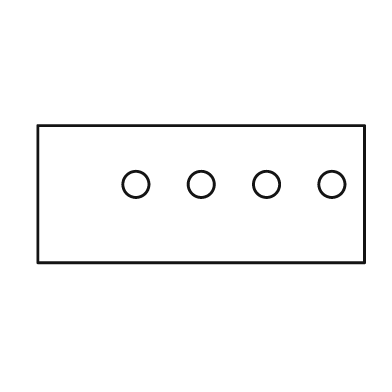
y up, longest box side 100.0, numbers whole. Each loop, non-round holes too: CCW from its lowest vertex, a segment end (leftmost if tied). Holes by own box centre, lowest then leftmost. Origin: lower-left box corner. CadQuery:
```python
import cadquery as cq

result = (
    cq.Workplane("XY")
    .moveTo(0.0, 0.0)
    .lineTo(100.0, 0.0)
    .lineTo(100.0, 42.0)
    .lineTo(0.0, 42.0)
    .close()
    .moveTo(30.0, 24.0)
    .circle(4.0)
    .moveTo(50.0, 24.0)
    .circle(4.0)
    .moveTo(70.0, 24.0)
    .circle(4.0)
    .moveTo(90.0, 24.0)
    .circle(4.0)
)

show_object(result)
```